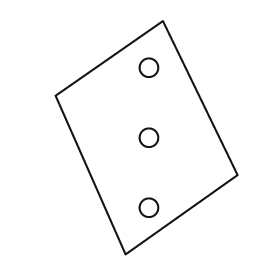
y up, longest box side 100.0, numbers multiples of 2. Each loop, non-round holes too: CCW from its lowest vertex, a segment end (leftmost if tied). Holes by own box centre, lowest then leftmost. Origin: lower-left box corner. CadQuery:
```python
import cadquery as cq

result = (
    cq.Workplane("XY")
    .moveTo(30.0, 0.0)
    .lineTo(78.0, 34.0)
    .lineTo(46.0, 100.0)
    .lineTo(0.0, 68.0)
    .close()
    .moveTo(40.0, 20.0)
    .circle(4.0)
    .moveTo(40.0, 50.0)
    .circle(4.0)
    .moveTo(40.0, 80.0)
    .circle(4.0)
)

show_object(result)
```